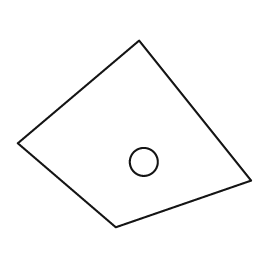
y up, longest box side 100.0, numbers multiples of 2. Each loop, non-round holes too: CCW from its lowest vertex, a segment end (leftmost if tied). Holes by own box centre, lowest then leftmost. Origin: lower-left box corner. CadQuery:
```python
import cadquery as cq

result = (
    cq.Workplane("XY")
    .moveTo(42.0, 0.0)
    .lineTo(100.0, 20.0)
    .lineTo(52.0, 80.0)
    .lineTo(0.0, 36.0)
    .close()
    .moveTo(54.0, 28.0)
    .circle(6.0)
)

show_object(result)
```